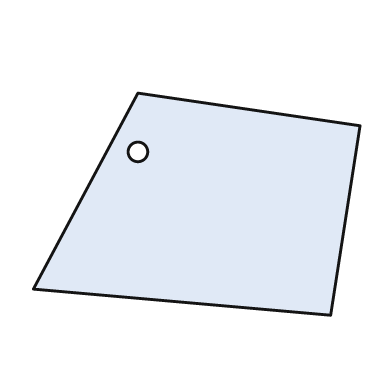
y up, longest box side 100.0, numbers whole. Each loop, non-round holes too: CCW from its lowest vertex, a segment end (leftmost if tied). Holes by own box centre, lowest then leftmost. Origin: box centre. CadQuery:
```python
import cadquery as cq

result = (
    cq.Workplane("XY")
    .moveTo(41.0, -34.0)
    .lineTo(50.0, 24.0)
    .lineTo(-18.0, 34.0)
    .lineTo(-50.0, -26.0)
    .close()
    .moveTo(-18.0, 16.0)
    .circle(3.0)
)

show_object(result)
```